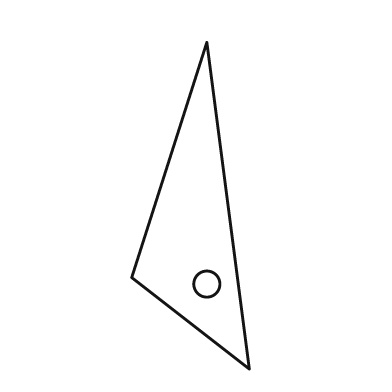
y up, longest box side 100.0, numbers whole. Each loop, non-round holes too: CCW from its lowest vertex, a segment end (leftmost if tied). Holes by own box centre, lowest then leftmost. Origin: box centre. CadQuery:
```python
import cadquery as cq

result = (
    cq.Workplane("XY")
    .moveTo(18.0, -50.0)
    .lineTo(5.0, 50.0)
    .lineTo(-18.0, -22.0)
    .close()
    .moveTo(5.0, -24.0)
    .circle(4.0)
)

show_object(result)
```